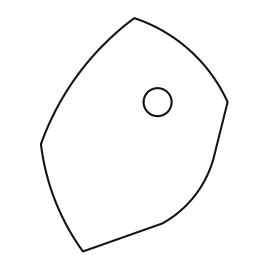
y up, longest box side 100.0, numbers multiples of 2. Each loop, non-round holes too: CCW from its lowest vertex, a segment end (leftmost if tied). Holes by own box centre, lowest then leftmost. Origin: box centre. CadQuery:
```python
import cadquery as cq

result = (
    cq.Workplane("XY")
    .moveTo(-22.0, -50.0)
    .lineTo(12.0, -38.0)
    .threePointArc((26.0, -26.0), (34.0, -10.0))
    .lineTo(40.0, 14.0)
    .threePointArc((24.0, 36.0), (0.0, 50.0))
    .threePointArc((-24.0, 26.0), (-40.0, -4.0))
    .threePointArc((-34.0, -28.0), (-22.0, -50.0))
    .close()
    .moveTo(10.0, 14.0)
    .circle(6.0)
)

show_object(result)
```